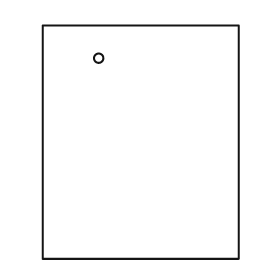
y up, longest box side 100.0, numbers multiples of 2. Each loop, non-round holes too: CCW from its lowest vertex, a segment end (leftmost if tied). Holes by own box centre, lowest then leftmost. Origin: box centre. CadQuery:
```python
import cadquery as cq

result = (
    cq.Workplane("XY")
    .moveTo(-42.0, -50.0)
    .lineTo(42.0, -50.0)
    .lineTo(42.0, 50.0)
    .lineTo(-42.0, 50.0)
    .close()
    .moveTo(-18.0, 36.0)
    .circle(2.0)
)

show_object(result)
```